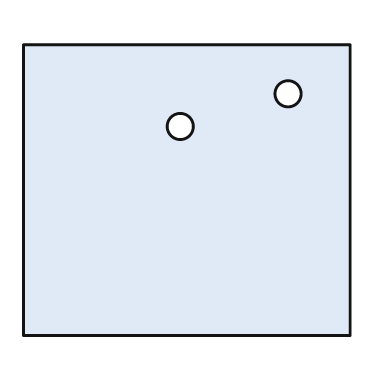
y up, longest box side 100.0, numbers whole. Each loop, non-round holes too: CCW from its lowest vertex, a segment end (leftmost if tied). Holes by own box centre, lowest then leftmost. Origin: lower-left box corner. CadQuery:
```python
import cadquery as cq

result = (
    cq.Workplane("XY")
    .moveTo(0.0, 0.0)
    .lineTo(100.0, 0.0)
    .lineTo(100.0, 89.0)
    .lineTo(0.0, 89.0)
    .close()
    .moveTo(48.0, 64.0)
    .circle(4.0)
    .moveTo(81.0, 74.0)
    .circle(4.0)
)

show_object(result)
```